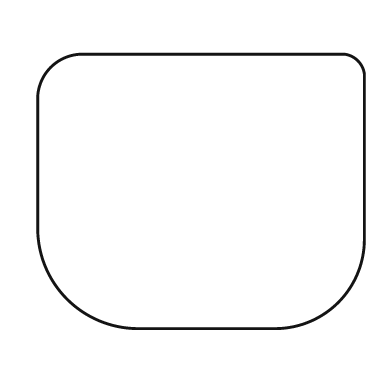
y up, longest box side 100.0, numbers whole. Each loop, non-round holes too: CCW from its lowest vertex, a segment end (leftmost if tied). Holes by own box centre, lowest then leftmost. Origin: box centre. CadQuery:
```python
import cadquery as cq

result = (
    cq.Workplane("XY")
    .moveTo(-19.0, -42.0)
    .lineTo(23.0, -42.0)
    .threePointArc((42.0, -34.0), (50.0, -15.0))
    .lineTo(50.0, 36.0)
    .threePointArc((48.0, 40.0), (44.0, 42.0))
    .lineTo(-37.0, 42.0)
    .threePointArc((-46.0, 38.0), (-50.0, 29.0))
    .lineTo(-50.0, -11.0)
    .threePointArc((-41.0, -33.0), (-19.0, -42.0))
    .close()
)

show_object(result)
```